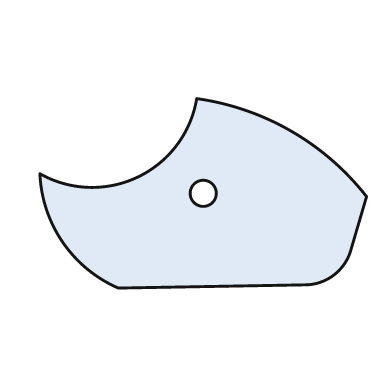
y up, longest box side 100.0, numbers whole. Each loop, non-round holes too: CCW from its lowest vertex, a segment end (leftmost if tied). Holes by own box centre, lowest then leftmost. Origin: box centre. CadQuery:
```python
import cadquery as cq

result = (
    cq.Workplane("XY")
    .moveTo(-26.0, -29.0)
    .lineTo(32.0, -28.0)
    .threePointArc((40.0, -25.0), (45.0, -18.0))
    .lineTo(50.0, -1.0)
    .threePointArc((27.0, 19.0), (-2.0, 29.0))
    .threePointArc((-20.0, 5.0), (-50.0, 6.0))
    .threePointArc((-43.0, -15.0), (-26.0, -29.0))
    .close()
    .moveTo(0.0, 0.0)
    .circle(4.0)
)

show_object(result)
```